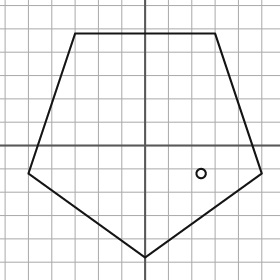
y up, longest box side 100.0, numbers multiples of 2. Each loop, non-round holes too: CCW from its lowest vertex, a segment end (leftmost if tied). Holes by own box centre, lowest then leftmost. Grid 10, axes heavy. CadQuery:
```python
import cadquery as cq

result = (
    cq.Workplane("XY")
    .moveTo(0.0, -48.0)
    .lineTo(50.0, -12.0)
    .lineTo(30.0, 48.0)
    .lineTo(-30.0, 48.0)
    .lineTo(-50.0, -12.0)
    .close()
    .moveTo(24.0, -12.0)
    .circle(2.0)
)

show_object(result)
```